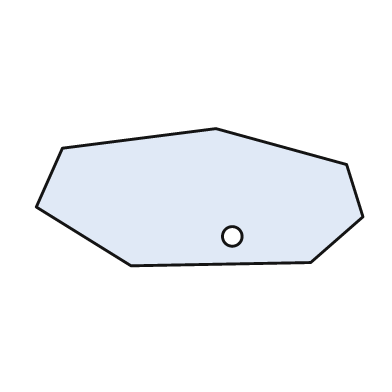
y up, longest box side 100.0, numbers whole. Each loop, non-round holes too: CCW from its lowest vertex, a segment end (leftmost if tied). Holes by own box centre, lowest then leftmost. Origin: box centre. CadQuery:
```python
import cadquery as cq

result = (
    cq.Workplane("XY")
    .moveTo(-21.0, -21.0)
    .lineTo(34.0, -20.0)
    .lineTo(50.0, -6.0)
    .lineTo(45.0, 10.0)
    .lineTo(5.0, 21.0)
    .lineTo(-42.0, 15.0)
    .lineTo(-50.0, -3.0)
    .close()
    .moveTo(10.0, -12.0)
    .circle(3.0)
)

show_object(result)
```